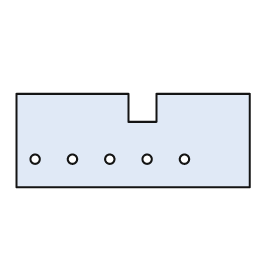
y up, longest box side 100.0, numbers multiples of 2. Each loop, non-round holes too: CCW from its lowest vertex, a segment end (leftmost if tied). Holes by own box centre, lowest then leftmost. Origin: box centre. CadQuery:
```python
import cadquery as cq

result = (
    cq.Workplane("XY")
    .moveTo(-50.0, -20.0)
    .lineTo(50.0, -20.0)
    .lineTo(50.0, 20.0)
    .lineTo(10.0, 20.0)
    .lineTo(10.0, 8.0)
    .lineTo(-2.0, 8.0)
    .lineTo(-2.0, 20.0)
    .lineTo(-50.0, 20.0)
    .close()
    .moveTo(-42.0, -8.0)
    .circle(2.0)
    .moveTo(-26.0, -8.0)
    .circle(2.0)
    .moveTo(-10.0, -8.0)
    .circle(2.0)
    .moveTo(6.0, -8.0)
    .circle(2.0)
    .moveTo(22.0, -8.0)
    .circle(2.0)
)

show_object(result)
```